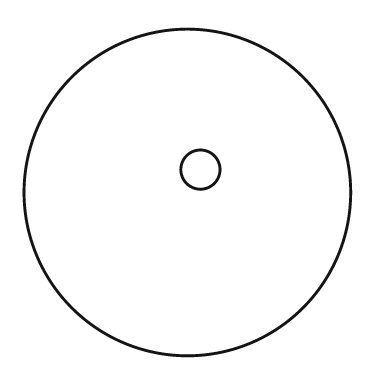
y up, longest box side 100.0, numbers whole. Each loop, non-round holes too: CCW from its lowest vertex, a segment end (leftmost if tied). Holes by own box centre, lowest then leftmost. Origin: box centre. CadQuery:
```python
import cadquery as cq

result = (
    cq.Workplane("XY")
    .moveTo(0.0, 0.0)
    .circle(50.0)
    .moveTo(4.0, 7.0)
    .circle(6.0)
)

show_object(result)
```